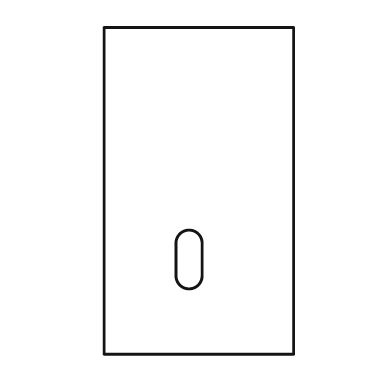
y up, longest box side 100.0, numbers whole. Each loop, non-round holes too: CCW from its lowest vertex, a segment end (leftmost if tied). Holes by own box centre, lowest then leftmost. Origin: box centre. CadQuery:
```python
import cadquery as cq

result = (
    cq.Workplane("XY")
    .moveTo(-29.0, -50.0)
    .lineTo(29.0, -50.0)
    .lineTo(29.0, 50.0)
    .lineTo(-29.0, 50.0)
    .close()
    .moveTo(-7.0, -26.0)
    .threePointArc((-3.0, -30.0), (1.0, -26.0))
    .lineTo(1.0, -16.0)
    .threePointArc((-3.0, -12.0), (-7.0, -16.0))
    .close()
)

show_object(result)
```